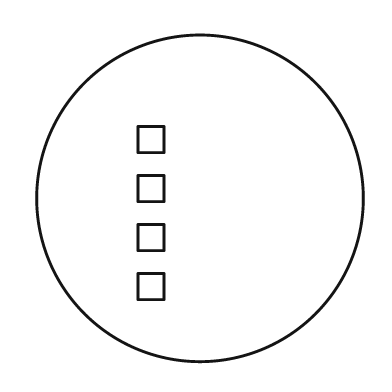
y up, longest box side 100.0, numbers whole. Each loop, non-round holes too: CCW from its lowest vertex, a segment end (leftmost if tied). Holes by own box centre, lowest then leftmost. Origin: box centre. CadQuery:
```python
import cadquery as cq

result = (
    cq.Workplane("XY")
    .moveTo(0.0, 0.0)
    .circle(50.0)
    .moveTo(-19.0, -31.0)
    .lineTo(-11.0, -31.0)
    .lineTo(-11.0, -23.0)
    .lineTo(-19.0, -23.0)
    .close()
    .moveTo(-19.0, -16.0)
    .lineTo(-11.0, -16.0)
    .lineTo(-11.0, -8.0)
    .lineTo(-19.0, -8.0)
    .close()
    .moveTo(-19.0, -1.0)
    .lineTo(-11.0, -1.0)
    .lineTo(-11.0, 7.0)
    .lineTo(-19.0, 7.0)
    .close()
    .moveTo(-19.0, 14.0)
    .lineTo(-11.0, 14.0)
    .lineTo(-11.0, 22.0)
    .lineTo(-19.0, 22.0)
    .close()
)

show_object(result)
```